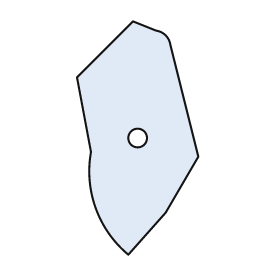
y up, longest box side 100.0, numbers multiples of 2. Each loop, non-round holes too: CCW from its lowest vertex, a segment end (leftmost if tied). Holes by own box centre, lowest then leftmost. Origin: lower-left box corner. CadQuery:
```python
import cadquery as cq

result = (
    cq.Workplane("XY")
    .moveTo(22.0, 0.0)
    .lineTo(38.0, 18.0)
    .lineTo(52.0, 42.0)
    .lineTo(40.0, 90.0)
    .threePointArc((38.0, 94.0), (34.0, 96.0))
    .lineTo(24.0, 100.0)
    .lineTo(0.0, 76.0)
    .lineTo(6.0, 44.0)
    .threePointArc((8.0, 20.0), (22.0, 0.0))
    .close()
    .moveTo(26.0, 50.0)
    .circle(4.0)
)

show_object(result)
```